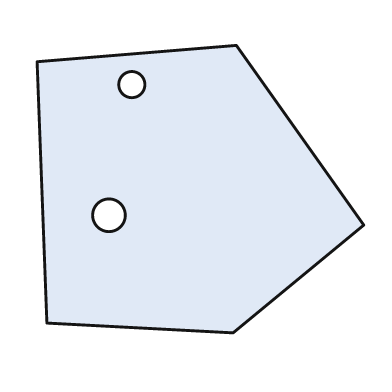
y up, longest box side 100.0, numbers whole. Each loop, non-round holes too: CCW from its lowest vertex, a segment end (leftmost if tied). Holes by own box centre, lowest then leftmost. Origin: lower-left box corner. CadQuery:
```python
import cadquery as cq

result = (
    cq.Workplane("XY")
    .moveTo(60.0, 0.0)
    .lineTo(100.0, 33.0)
    .lineTo(61.0, 88.0)
    .lineTo(0.0, 83.0)
    .lineTo(3.0, 3.0)
    .close()
    .moveTo(22.0, 36.0)
    .circle(5.0)
    .moveTo(29.0, 76.0)
    .circle(4.0)
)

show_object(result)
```